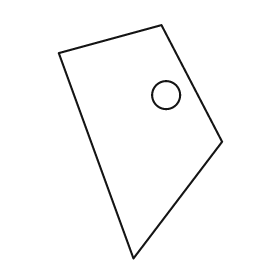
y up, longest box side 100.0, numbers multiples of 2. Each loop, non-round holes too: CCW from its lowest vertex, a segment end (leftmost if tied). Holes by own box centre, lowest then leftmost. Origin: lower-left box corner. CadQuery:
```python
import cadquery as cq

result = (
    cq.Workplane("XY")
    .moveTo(32.0, 0.0)
    .lineTo(70.0, 50.0)
    .lineTo(44.0, 100.0)
    .lineTo(0.0, 88.0)
    .close()
    .moveTo(46.0, 70.0)
    .circle(6.0)
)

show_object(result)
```